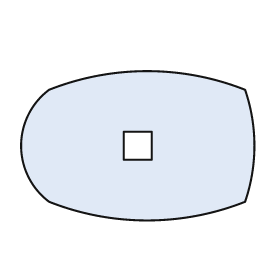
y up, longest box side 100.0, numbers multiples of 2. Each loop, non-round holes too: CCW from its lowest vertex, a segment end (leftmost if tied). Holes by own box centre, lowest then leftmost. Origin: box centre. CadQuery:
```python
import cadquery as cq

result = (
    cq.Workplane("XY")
    .moveTo(-38.0, -24.0)
    .threePointArc((4.0, -32.0), (46.0, -24.0))
    .threePointArc((50.0, 0.0), (46.0, 24.0))
    .threePointArc((4.0, 32.0), (-38.0, 24.0))
    .threePointArc((-50.0, 0.0), (-38.0, -24.0))
    .close()
    .moveTo(-6.0, -6.0)
    .lineTo(6.0, -6.0)
    .lineTo(6.0, 6.0)
    .lineTo(-6.0, 6.0)
    .close()
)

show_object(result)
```